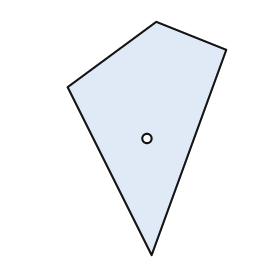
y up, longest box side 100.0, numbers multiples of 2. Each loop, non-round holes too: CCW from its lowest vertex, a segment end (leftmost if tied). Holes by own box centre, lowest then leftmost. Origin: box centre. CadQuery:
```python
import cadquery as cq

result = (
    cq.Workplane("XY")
    .moveTo(2.0, -50.0)
    .lineTo(34.0, 38.0)
    .lineTo(4.0, 50.0)
    .lineTo(-34.0, 22.0)
    .close()
    .moveTo(0.0, 0.0)
    .circle(2.0)
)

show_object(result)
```